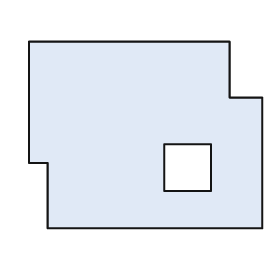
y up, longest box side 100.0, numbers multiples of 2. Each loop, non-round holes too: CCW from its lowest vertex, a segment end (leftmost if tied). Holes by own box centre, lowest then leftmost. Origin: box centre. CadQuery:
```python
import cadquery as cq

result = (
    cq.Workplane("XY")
    .moveTo(-42.0, -40.0)
    .lineTo(50.0, -40.0)
    .lineTo(50.0, 16.0)
    .lineTo(36.0, 16.0)
    .lineTo(36.0, 40.0)
    .lineTo(-50.0, 40.0)
    .lineTo(-50.0, -12.0)
    .lineTo(-42.0, -12.0)
    .close()
    .moveTo(8.0, -24.0)
    .lineTo(28.0, -24.0)
    .lineTo(28.0, -4.0)
    .lineTo(8.0, -4.0)
    .close()
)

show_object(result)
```